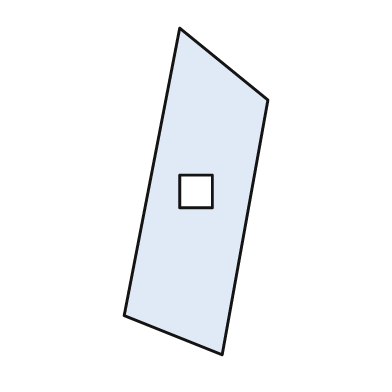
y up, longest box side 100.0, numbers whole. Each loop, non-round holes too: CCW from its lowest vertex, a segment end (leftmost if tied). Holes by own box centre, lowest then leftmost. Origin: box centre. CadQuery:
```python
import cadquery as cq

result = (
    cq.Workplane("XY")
    .moveTo(8.0, -50.0)
    .lineTo(22.0, 28.0)
    .lineTo(-5.0, 50.0)
    .lineTo(-22.0, -38.0)
    .close()
    .moveTo(-5.0, -5.0)
    .lineTo(5.0, -5.0)
    .lineTo(5.0, 5.0)
    .lineTo(-5.0, 5.0)
    .close()
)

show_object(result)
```